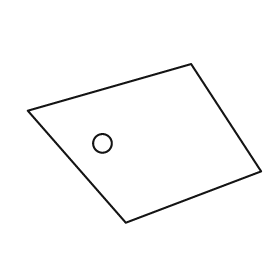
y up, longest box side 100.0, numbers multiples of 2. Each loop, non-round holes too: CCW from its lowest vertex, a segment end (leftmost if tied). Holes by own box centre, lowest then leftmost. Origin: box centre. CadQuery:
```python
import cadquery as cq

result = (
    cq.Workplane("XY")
    .moveTo(-8.0, -34.0)
    .lineTo(50.0, -12.0)
    .lineTo(20.0, 34.0)
    .lineTo(-50.0, 14.0)
    .close()
    .moveTo(-18.0, 0.0)
    .circle(4.0)
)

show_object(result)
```